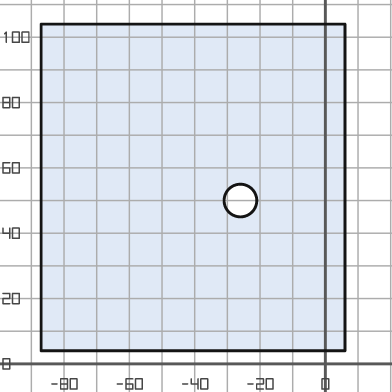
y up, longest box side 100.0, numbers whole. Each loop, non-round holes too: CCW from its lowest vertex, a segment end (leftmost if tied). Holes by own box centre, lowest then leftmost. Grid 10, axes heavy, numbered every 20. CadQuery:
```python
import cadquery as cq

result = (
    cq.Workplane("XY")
    .moveTo(-87.0, 4.0)
    .lineTo(6.0, 4.0)
    .lineTo(6.0, 104.0)
    .lineTo(-87.0, 104.0)
    .close()
    .moveTo(-26.0, 50.0)
    .circle(5.0)
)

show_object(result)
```